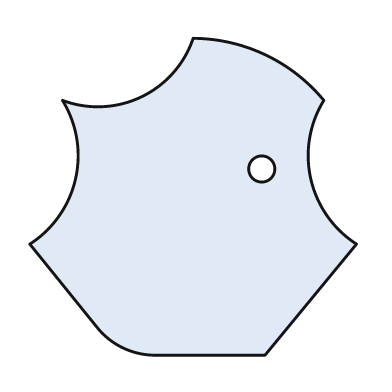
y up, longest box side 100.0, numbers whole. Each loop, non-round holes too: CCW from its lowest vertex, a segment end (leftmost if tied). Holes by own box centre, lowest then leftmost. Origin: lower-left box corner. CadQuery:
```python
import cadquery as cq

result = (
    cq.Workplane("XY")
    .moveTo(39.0, 0.0)
    .lineTo(72.0, 0.0)
    .lineTo(100.0, 34.0)
    .threePointArc((86.0, 54.0), (90.0, 78.0))
    .threePointArc((72.0, 92.0), (50.0, 97.0))
    .threePointArc((34.0, 79.0), (10.0, 78.0))
    .threePointArc((14.0, 54.0), (0.0, 34.0))
    .lineTo(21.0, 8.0)
    .threePointArc((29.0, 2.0), (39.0, 0.0))
    .close()
    .moveTo(71.0, 57.0)
    .circle(4.0)
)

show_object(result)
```